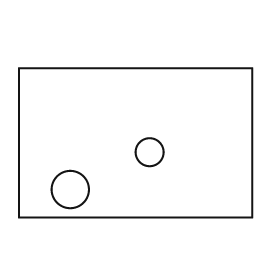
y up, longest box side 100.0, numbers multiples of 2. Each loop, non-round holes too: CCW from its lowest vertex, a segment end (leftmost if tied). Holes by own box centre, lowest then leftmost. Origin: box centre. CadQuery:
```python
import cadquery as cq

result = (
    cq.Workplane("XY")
    .moveTo(-50.0, -32.0)
    .lineTo(50.0, -32.0)
    .lineTo(50.0, 32.0)
    .lineTo(-50.0, 32.0)
    .close()
    .moveTo(-28.0, -20.0)
    .circle(8.0)
    .moveTo(6.0, -4.0)
    .circle(6.0)
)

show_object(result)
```